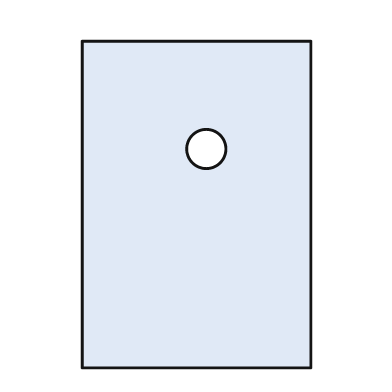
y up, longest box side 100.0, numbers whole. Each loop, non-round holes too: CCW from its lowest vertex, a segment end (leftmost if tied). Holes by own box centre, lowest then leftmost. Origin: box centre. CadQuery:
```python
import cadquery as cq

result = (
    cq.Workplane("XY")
    .moveTo(-35.0, -50.0)
    .lineTo(35.0, -50.0)
    .lineTo(35.0, 50.0)
    .lineTo(-35.0, 50.0)
    .close()
    .moveTo(3.0, 17.0)
    .circle(6.0)
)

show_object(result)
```